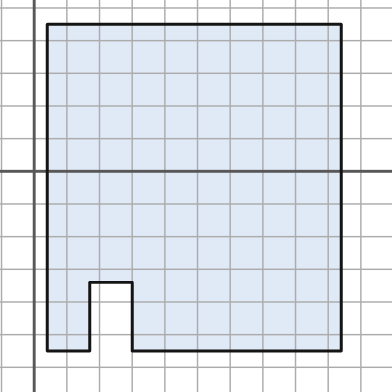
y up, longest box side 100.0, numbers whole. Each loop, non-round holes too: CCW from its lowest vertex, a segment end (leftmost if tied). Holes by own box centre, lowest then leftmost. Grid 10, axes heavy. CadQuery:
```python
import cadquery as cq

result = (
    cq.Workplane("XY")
    .moveTo(4.0, -55.0)
    .lineTo(17.0, -55.0)
    .lineTo(17.0, -34.0)
    .lineTo(30.0, -34.0)
    .lineTo(30.0, -55.0)
    .lineTo(94.0, -55.0)
    .lineTo(94.0, 45.0)
    .lineTo(4.0, 45.0)
    .close()
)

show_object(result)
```